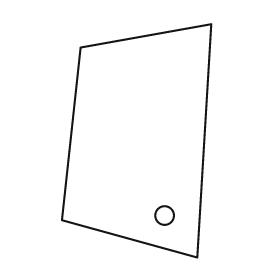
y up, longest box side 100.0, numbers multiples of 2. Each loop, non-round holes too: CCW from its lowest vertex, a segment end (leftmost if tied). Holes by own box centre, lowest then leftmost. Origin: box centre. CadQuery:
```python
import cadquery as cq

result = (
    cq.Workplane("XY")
    .moveTo(26.0, -50.0)
    .lineTo(32.0, 50.0)
    .lineTo(-24.0, 40.0)
    .lineTo(-32.0, -34.0)
    .close()
    .moveTo(12.0, -32.0)
    .circle(4.0)
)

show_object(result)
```